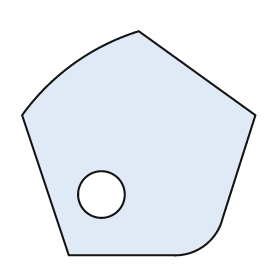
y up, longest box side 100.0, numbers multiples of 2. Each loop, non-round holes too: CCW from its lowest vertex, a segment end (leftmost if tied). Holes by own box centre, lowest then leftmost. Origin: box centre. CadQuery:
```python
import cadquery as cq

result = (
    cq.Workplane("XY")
    .moveTo(-30.0, -48.0)
    .lineTo(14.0, -48.0)
    .threePointArc((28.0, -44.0), (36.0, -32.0))
    .lineTo(50.0, 12.0)
    .lineTo(0.0, 48.0)
    .threePointArc((-28.0, 34.0), (-50.0, 12.0))
    .close()
    .moveTo(-16.0, -22.0)
    .circle(10.0)
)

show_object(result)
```